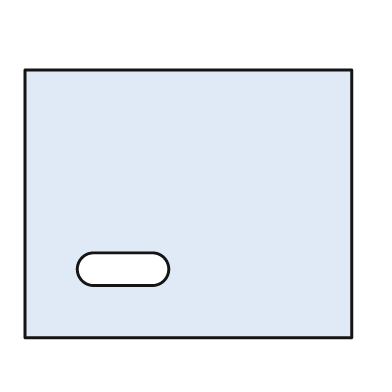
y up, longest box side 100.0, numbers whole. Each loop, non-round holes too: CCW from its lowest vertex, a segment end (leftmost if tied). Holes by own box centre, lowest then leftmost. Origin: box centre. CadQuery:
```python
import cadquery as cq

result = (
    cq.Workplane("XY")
    .moveTo(-50.0, -41.0)
    .lineTo(50.0, -41.0)
    .lineTo(50.0, 41.0)
    .lineTo(-50.0, 41.0)
    .close()
    .moveTo(-29.0, -25.0)
    .lineTo(-11.0, -25.0)
    .threePointArc((-6.0, -20.0), (-11.0, -15.0))
    .lineTo(-29.0, -15.0)
    .threePointArc((-34.0, -20.0), (-29.0, -25.0))
    .close()
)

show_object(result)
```